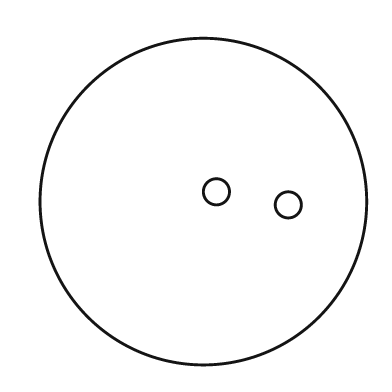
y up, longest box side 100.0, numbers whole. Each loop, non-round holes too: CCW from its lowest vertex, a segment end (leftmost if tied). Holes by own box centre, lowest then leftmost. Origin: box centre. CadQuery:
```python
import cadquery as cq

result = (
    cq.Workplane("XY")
    .moveTo(0.0, 0.0)
    .circle(50.0)
    .moveTo(26.0, -1.0)
    .circle(4.0)
    .moveTo(4.0, 3.0)
    .circle(4.0)
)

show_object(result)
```